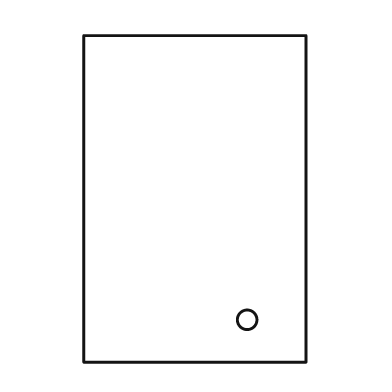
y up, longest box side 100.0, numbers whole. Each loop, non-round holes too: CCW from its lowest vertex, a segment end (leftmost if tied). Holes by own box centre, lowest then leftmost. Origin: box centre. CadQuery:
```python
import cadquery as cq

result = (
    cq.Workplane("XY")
    .moveTo(-34.0, -50.0)
    .lineTo(34.0, -50.0)
    .lineTo(34.0, 50.0)
    .lineTo(-34.0, 50.0)
    .close()
    .moveTo(16.0, -37.0)
    .circle(3.0)
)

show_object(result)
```